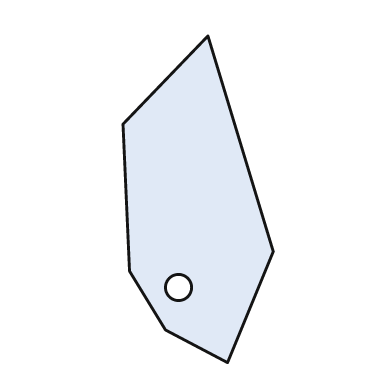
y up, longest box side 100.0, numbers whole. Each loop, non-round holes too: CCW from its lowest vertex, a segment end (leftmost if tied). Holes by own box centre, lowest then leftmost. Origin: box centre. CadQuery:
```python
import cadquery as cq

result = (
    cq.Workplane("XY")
    .moveTo(9.0, -50.0)
    .lineTo(23.0, -16.0)
    .lineTo(3.0, 50.0)
    .lineTo(-23.0, 23.0)
    .lineTo(-21.0, -22.0)
    .lineTo(-10.0, -40.0)
    .close()
    .moveTo(-6.0, -27.0)
    .circle(4.0)
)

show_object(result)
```